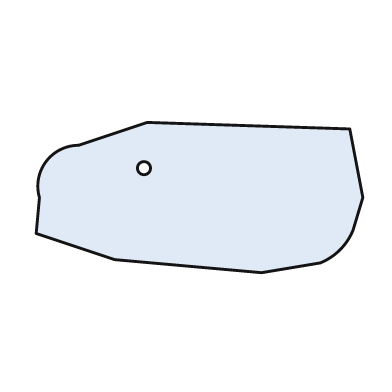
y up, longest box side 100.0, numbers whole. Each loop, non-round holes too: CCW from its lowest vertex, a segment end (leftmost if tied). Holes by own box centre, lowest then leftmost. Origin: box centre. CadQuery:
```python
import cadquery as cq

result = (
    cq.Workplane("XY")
    .moveTo(19.0, -23.0)
    .lineTo(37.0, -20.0)
    .threePointArc((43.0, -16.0), (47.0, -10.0))
    .lineTo(50.0, 0.0)
    .lineTo(46.0, 21.0)
    .lineTo(-16.0, 23.0)
    .lineTo(-37.0, 16.0)
    .threePointArc((-47.0, 11.0), (-49.0, 0.0))
    .lineTo(-50.0, -11.0)
    .lineTo(-26.0, -19.0)
    .close()
    .moveTo(-17.0, 9.0)
    .circle(2.0)
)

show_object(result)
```